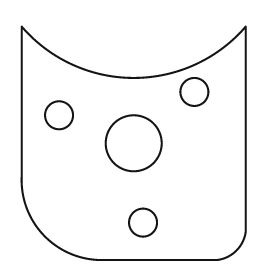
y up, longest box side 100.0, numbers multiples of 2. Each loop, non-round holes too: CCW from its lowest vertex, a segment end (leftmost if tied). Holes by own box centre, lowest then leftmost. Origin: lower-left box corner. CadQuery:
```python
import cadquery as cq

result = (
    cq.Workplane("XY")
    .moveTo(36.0, 0.0)
    .lineTo(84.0, 0.0)
    .threePointArc((92.0, 4.0), (96.0, 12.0))
    .lineTo(96.0, 100.0)
    .threePointArc((48.0, 78.0), (0.0, 100.0))
    .lineTo(0.0, 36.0)
    .threePointArc((10.0, 10.0), (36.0, 0.0))
    .close()
    .moveTo(52.0, 16.0)
    .circle(6.0)
    .moveTo(48.0, 50.0)
    .circle(12.0)
    .moveTo(16.0, 62.0)
    .circle(6.0)
    .moveTo(74.0, 72.0)
    .circle(6.0)
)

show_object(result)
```